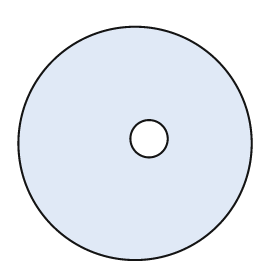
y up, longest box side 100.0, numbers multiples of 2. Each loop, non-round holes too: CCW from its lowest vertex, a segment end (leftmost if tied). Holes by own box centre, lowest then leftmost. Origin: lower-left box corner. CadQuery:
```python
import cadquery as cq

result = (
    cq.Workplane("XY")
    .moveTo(50.0, 50.0)
    .circle(50.0)
    .moveTo(56.0, 52.0)
    .circle(8.0)
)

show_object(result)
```